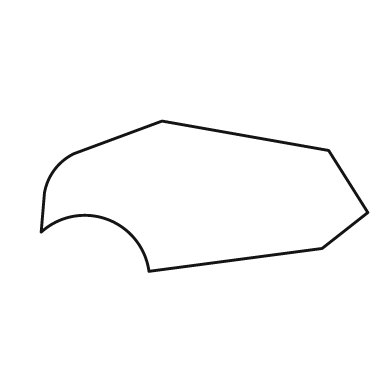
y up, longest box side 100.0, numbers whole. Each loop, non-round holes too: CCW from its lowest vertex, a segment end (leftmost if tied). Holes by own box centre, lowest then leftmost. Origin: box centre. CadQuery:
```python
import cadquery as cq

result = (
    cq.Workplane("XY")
    .moveTo(-17.0, -23.0)
    .lineTo(36.0, -16.0)
    .lineTo(50.0, -5.0)
    .lineTo(38.0, 14.0)
    .lineTo(-13.0, 23.0)
    .lineTo(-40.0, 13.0)
    .threePointArc((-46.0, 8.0), (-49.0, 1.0))
    .lineTo(-50.0, -11.0)
    .threePointArc((-30.0, -7.0), (-17.0, -23.0))
    .close()
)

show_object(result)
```